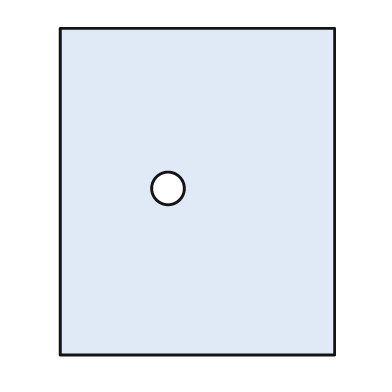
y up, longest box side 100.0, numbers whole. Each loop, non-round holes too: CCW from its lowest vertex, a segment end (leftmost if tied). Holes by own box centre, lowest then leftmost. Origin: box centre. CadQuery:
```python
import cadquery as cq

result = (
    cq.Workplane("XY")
    .moveTo(-42.0, -50.0)
    .lineTo(42.0, -50.0)
    .lineTo(42.0, 50.0)
    .lineTo(-42.0, 50.0)
    .close()
    .moveTo(-9.0, 1.0)
    .circle(5.0)
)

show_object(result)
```